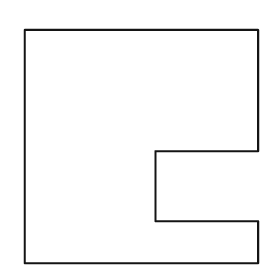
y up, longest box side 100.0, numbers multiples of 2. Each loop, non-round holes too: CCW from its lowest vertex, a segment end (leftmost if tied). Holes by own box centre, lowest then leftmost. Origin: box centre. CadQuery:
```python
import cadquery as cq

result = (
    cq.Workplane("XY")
    .moveTo(-50.0, -50.0)
    .lineTo(50.0, -50.0)
    .lineTo(50.0, -32.0)
    .lineTo(6.0, -32.0)
    .lineTo(6.0, -2.0)
    .lineTo(50.0, -2.0)
    .lineTo(50.0, 50.0)
    .lineTo(-50.0, 50.0)
    .close()
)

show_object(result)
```